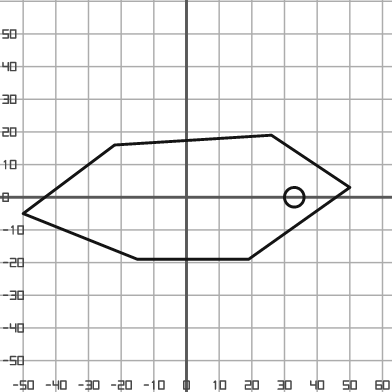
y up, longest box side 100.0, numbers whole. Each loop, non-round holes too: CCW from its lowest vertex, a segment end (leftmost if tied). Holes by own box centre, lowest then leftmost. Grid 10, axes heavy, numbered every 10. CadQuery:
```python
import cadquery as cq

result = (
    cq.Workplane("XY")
    .moveTo(-15.0, -19.0)
    .lineTo(19.0, -19.0)
    .lineTo(50.0, 3.0)
    .lineTo(26.0, 19.0)
    .lineTo(-22.0, 16.0)
    .lineTo(-50.0, -5.0)
    .close()
    .moveTo(33.0, 0.0)
    .circle(3.0)
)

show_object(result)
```